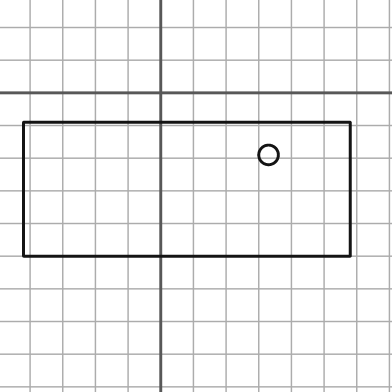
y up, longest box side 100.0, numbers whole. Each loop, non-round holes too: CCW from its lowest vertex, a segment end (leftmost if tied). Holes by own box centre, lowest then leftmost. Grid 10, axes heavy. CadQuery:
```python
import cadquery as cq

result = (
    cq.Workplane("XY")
    .moveTo(-42.0, -50.0)
    .lineTo(58.0, -50.0)
    .lineTo(58.0, -9.0)
    .lineTo(-42.0, -9.0)
    .close()
    .moveTo(33.0, -19.0)
    .circle(3.0)
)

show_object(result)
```